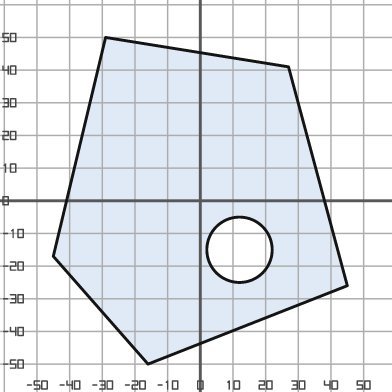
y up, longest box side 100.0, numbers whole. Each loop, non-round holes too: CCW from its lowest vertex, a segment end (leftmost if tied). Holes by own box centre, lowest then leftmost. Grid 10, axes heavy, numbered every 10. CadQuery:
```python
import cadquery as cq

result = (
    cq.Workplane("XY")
    .moveTo(-16.0, -50.0)
    .lineTo(45.0, -26.0)
    .lineTo(27.0, 41.0)
    .lineTo(-29.0, 50.0)
    .lineTo(-45.0, -17.0)
    .close()
    .moveTo(12.0, -15.0)
    .circle(10.0)
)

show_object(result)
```